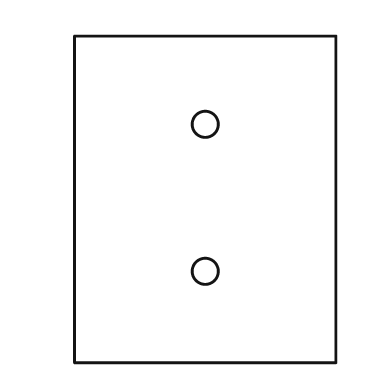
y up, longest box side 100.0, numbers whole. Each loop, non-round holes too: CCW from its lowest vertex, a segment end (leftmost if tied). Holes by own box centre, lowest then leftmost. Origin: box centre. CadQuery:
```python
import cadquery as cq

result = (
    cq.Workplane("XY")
    .moveTo(-40.0, -50.0)
    .lineTo(40.0, -50.0)
    .lineTo(40.0, 50.0)
    .lineTo(-40.0, 50.0)
    .close()
    .moveTo(0.0, -22.0)
    .circle(4.0)
    .moveTo(0.0, 23.0)
    .circle(4.0)
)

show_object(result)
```